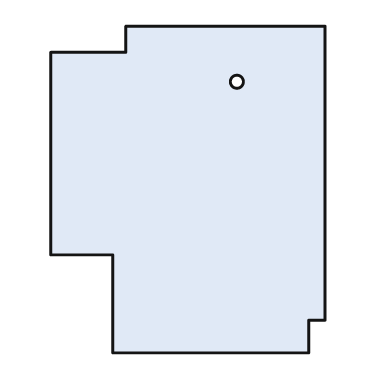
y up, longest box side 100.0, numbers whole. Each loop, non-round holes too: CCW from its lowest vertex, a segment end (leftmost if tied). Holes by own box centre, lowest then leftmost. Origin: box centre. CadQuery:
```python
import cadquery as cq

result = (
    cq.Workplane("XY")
    .moveTo(-23.0, -50.0)
    .lineTo(37.0, -50.0)
    .lineTo(37.0, -40.0)
    .lineTo(42.0, -40.0)
    .lineTo(42.0, 50.0)
    .lineTo(-19.0, 50.0)
    .lineTo(-19.0, 42.0)
    .lineTo(-42.0, 42.0)
    .lineTo(-42.0, -20.0)
    .lineTo(-23.0, -20.0)
    .close()
    .moveTo(15.0, 33.0)
    .circle(2.0)
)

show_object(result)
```